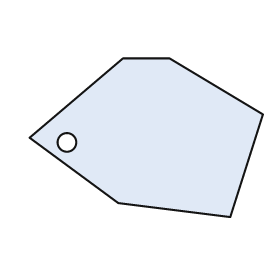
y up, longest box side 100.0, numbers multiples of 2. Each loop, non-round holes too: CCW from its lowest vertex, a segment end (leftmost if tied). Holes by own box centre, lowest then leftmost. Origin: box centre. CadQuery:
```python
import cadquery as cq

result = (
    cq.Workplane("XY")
    .moveTo(36.0, -34.0)
    .lineTo(50.0, 10.0)
    .lineTo(10.0, 34.0)
    .lineTo(-10.0, 34.0)
    .lineTo(-50.0, 0.0)
    .lineTo(-12.0, -28.0)
    .close()
    .moveTo(-34.0, -2.0)
    .circle(4.0)
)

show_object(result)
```